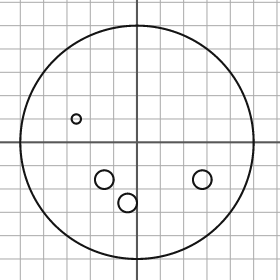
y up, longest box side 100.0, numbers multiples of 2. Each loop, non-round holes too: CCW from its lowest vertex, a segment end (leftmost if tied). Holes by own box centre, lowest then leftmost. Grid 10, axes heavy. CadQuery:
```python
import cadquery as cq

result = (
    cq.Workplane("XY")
    .moveTo(0.0, 0.0)
    .circle(50.0)
    .moveTo(-4.0, -26.0)
    .circle(4.0)
    .moveTo(-14.0, -16.0)
    .circle(4.0)
    .moveTo(28.0, -16.0)
    .circle(4.0)
    .moveTo(-26.0, 10.0)
    .circle(2.0)
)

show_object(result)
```